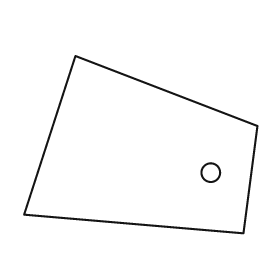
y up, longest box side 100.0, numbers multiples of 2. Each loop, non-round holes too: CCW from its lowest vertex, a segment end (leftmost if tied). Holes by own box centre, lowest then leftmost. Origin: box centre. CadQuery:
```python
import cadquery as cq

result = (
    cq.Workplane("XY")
    .moveTo(44.0, -38.0)
    .lineTo(50.0, 8.0)
    .lineTo(-28.0, 38.0)
    .lineTo(-50.0, -30.0)
    .close()
    .moveTo(30.0, -12.0)
    .circle(4.0)
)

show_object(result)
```